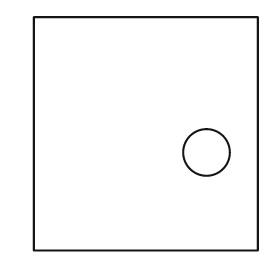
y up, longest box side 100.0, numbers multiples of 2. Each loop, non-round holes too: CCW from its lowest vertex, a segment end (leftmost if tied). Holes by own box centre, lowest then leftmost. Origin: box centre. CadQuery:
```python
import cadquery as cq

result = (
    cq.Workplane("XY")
    .moveTo(-48.0, -50.0)
    .lineTo(48.0, -50.0)
    .lineTo(48.0, 50.0)
    .lineTo(-48.0, 50.0)
    .close()
    .moveTo(26.0, -8.0)
    .circle(10.0)
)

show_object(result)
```